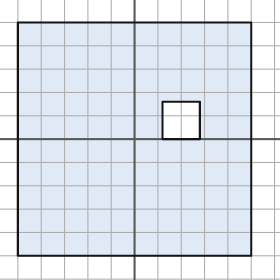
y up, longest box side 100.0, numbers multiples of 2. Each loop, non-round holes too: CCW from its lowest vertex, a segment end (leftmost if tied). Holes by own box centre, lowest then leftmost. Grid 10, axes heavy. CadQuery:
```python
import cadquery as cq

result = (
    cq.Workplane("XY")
    .moveTo(-50.0, -50.0)
    .lineTo(50.0, -50.0)
    .lineTo(50.0, 50.0)
    .lineTo(-50.0, 50.0)
    .close()
    .moveTo(12.0, 0.0)
    .lineTo(28.0, 0.0)
    .lineTo(28.0, 16.0)
    .lineTo(12.0, 16.0)
    .close()
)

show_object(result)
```